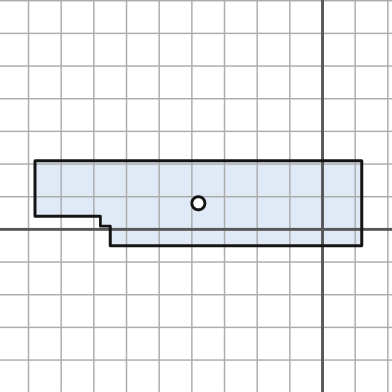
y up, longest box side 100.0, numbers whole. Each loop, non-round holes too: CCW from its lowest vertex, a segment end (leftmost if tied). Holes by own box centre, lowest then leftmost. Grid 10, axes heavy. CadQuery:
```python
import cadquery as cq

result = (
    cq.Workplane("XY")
    .moveTo(-65.0, -5.0)
    .lineTo(12.0, -5.0)
    .lineTo(12.0, 21.0)
    .lineTo(-88.0, 21.0)
    .lineTo(-88.0, 4.0)
    .lineTo(-68.0, 4.0)
    .lineTo(-68.0, 1.0)
    .lineTo(-65.0, 1.0)
    .close()
    .moveTo(-38.0, 8.0)
    .circle(2.0)
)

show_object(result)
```